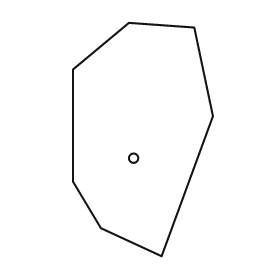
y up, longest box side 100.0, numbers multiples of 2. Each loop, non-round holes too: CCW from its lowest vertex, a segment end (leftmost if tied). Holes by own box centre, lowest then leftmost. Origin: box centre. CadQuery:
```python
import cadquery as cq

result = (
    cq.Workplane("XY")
    .moveTo(8.0, -50.0)
    .lineTo(30.0, 10.0)
    .lineTo(22.0, 48.0)
    .lineTo(-6.0, 50.0)
    .lineTo(-30.0, 30.0)
    .lineTo(-30.0, -18.0)
    .lineTo(-18.0, -38.0)
    .close()
    .moveTo(-4.0, -8.0)
    .circle(2.0)
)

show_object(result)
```